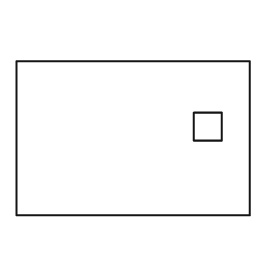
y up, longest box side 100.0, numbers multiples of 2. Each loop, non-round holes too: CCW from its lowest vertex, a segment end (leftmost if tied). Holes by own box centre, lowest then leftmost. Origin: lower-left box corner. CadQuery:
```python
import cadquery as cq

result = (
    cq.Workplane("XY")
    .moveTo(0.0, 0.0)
    .lineTo(100.0, 0.0)
    .lineTo(100.0, 66.0)
    .lineTo(0.0, 66.0)
    .close()
    .moveTo(76.0, 32.0)
    .lineTo(88.0, 32.0)
    .lineTo(88.0, 44.0)
    .lineTo(76.0, 44.0)
    .close()
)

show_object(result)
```